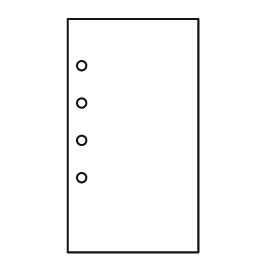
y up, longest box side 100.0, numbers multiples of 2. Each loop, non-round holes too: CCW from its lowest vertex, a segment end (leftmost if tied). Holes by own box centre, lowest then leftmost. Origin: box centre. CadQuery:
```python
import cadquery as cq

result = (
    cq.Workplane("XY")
    .moveTo(-28.0, -50.0)
    .lineTo(28.0, -50.0)
    .lineTo(28.0, 50.0)
    .lineTo(-28.0, 50.0)
    .close()
    .moveTo(-22.0, -18.0)
    .circle(2.0)
    .moveTo(-22.0, -2.0)
    .circle(2.0)
    .moveTo(-22.0, 14.0)
    .circle(2.0)
    .moveTo(-22.0, 30.0)
    .circle(2.0)
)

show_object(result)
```